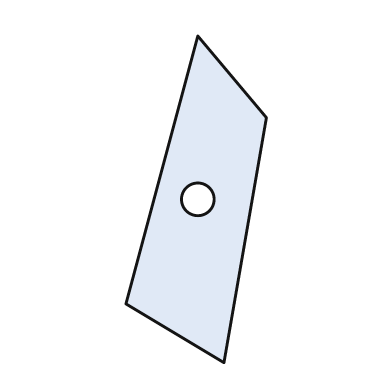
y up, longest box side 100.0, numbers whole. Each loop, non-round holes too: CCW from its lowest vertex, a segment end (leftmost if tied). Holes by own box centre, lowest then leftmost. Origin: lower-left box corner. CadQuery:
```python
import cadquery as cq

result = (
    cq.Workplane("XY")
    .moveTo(30.0, 0.0)
    .lineTo(43.0, 75.0)
    .lineTo(22.0, 100.0)
    .lineTo(0.0, 18.0)
    .close()
    .moveTo(22.0, 50.0)
    .circle(5.0)
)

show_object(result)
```